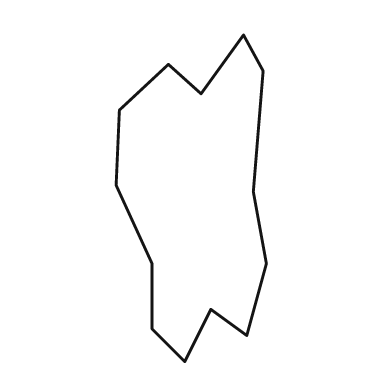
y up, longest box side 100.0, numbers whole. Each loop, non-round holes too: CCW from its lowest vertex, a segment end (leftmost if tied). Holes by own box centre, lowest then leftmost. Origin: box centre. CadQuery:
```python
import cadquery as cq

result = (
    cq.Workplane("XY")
    .moveTo(-2.0, -50.0)
    .lineTo(6.0, -34.0)
    .lineTo(17.0, -42.0)
    .lineTo(23.0, -20.0)
    .lineTo(19.0, 2.0)
    .lineTo(22.0, 39.0)
    .lineTo(16.0, 50.0)
    .lineTo(3.0, 32.0)
    .lineTo(-7.0, 41.0)
    .lineTo(-22.0, 27.0)
    .lineTo(-23.0, 4.0)
    .lineTo(-12.0, -20.0)
    .lineTo(-12.0, -40.0)
    .close()
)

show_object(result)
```